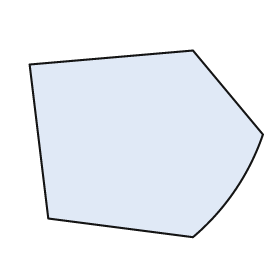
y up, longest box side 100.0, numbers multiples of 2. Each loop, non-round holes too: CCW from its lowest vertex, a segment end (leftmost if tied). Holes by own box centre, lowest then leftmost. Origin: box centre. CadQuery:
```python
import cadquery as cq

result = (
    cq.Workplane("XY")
    .moveTo(20.0, -40.0)
    .threePointArc((38.0, -20.0), (50.0, 4.0))
    .lineTo(20.0, 40.0)
    .lineTo(-50.0, 34.0)
    .lineTo(-42.0, -32.0)
    .close()
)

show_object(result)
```